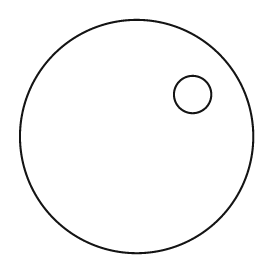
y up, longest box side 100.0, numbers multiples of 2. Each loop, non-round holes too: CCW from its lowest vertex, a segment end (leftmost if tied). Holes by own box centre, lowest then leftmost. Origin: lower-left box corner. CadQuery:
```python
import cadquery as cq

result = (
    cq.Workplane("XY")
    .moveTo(50.0, 50.0)
    .circle(50.0)
    .moveTo(74.0, 68.0)
    .circle(8.0)
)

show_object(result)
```